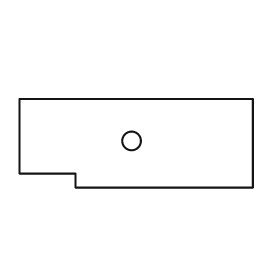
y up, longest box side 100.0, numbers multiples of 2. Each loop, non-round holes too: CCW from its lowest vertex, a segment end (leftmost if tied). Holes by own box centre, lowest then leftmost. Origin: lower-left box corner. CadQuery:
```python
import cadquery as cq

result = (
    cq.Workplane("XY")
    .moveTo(24.0, 0.0)
    .lineTo(100.0, 0.0)
    .lineTo(100.0, 38.0)
    .lineTo(0.0, 38.0)
    .lineTo(0.0, 6.0)
    .lineTo(24.0, 6.0)
    .close()
    .moveTo(48.0, 20.0)
    .circle(4.0)
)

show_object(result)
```